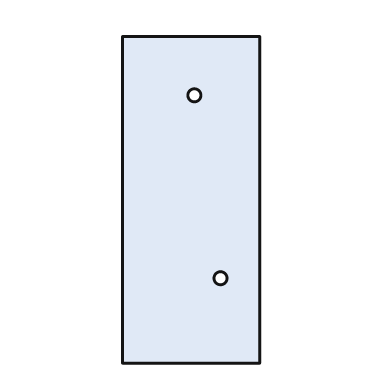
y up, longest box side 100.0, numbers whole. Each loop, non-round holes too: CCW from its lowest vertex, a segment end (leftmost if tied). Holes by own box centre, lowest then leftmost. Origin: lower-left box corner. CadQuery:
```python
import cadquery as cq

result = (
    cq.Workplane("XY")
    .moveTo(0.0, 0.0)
    .lineTo(42.0, 0.0)
    .lineTo(42.0, 100.0)
    .lineTo(0.0, 100.0)
    .close()
    .moveTo(30.0, 26.0)
    .circle(2.0)
    .moveTo(22.0, 82.0)
    .circle(2.0)
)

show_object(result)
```